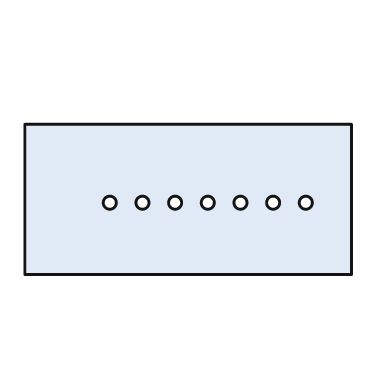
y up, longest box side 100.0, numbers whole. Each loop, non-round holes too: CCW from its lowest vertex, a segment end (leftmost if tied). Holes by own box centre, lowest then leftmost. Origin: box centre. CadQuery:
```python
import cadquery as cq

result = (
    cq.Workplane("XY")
    .moveTo(-50.0, -23.0)
    .lineTo(50.0, -23.0)
    .lineTo(50.0, 23.0)
    .lineTo(-50.0, 23.0)
    .close()
    .moveTo(-24.0, -1.0)
    .circle(2.0)
    .moveTo(-14.0, -1.0)
    .circle(2.0)
    .moveTo(-4.0, -1.0)
    .circle(2.0)
    .moveTo(6.0, -1.0)
    .circle(2.0)
    .moveTo(16.0, -1.0)
    .circle(2.0)
    .moveTo(26.0, -1.0)
    .circle(2.0)
    .moveTo(36.0, -1.0)
    .circle(2.0)
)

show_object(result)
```